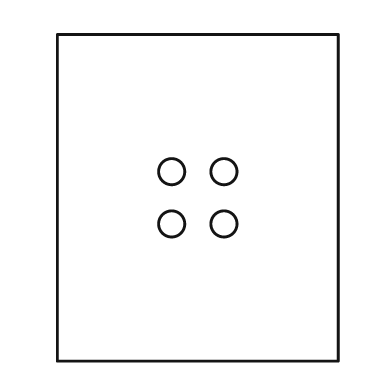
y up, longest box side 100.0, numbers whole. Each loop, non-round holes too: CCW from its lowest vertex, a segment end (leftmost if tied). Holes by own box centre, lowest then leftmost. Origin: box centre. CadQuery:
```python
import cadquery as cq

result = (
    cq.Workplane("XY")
    .moveTo(-43.0, -50.0)
    .lineTo(43.0, -50.0)
    .lineTo(43.0, 50.0)
    .lineTo(-43.0, 50.0)
    .close()
    .moveTo(-8.0, -8.0)
    .circle(4.0)
    .moveTo(8.0, -8.0)
    .circle(4.0)
    .moveTo(-8.0, 8.0)
    .circle(4.0)
    .moveTo(8.0, 8.0)
    .circle(4.0)
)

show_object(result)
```